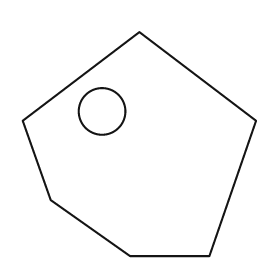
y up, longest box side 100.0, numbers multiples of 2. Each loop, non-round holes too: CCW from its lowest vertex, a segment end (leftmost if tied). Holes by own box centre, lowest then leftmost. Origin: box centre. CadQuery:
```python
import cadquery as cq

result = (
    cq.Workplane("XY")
    .moveTo(-4.0, -48.0)
    .lineTo(30.0, -48.0)
    .lineTo(50.0, 10.0)
    .lineTo(0.0, 48.0)
    .lineTo(-50.0, 10.0)
    .lineTo(-38.0, -24.0)
    .close()
    .moveTo(-16.0, 14.0)
    .circle(10.0)
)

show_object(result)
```